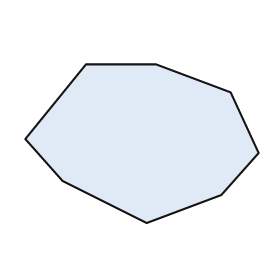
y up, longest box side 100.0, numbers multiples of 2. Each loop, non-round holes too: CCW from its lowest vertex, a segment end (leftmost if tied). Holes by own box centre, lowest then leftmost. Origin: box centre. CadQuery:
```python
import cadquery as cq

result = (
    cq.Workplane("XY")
    .moveTo(2.0, -34.0)
    .lineTo(34.0, -22.0)
    .lineTo(50.0, -4.0)
    .lineTo(38.0, 22.0)
    .lineTo(6.0, 34.0)
    .lineTo(-24.0, 34.0)
    .lineTo(-50.0, 2.0)
    .lineTo(-34.0, -16.0)
    .close()
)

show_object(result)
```